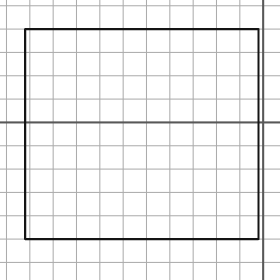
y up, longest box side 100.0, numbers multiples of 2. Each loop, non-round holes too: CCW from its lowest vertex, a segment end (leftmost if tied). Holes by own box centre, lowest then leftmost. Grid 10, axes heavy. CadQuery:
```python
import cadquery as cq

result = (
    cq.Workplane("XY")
    .moveTo(-102.0, -50.0)
    .lineTo(-2.0, -50.0)
    .lineTo(-2.0, 40.0)
    .lineTo(-102.0, 40.0)
    .close()
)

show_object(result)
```